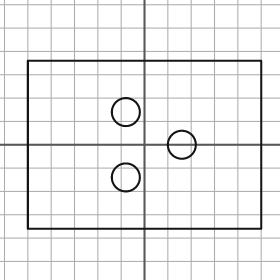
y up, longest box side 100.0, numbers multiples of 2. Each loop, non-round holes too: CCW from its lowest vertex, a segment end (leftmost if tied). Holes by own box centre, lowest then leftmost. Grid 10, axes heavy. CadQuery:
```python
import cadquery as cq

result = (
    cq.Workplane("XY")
    .moveTo(-50.0, -36.0)
    .lineTo(50.0, -36.0)
    .lineTo(50.0, 36.0)
    .lineTo(-50.0, 36.0)
    .close()
    .moveTo(-8.0, -14.0)
    .circle(6.0)
    .moveTo(16.0, 0.0)
    .circle(6.0)
    .moveTo(-8.0, 14.0)
    .circle(6.0)
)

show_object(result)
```